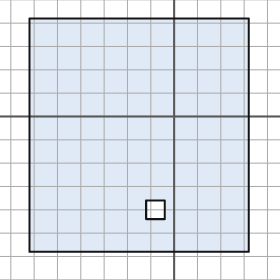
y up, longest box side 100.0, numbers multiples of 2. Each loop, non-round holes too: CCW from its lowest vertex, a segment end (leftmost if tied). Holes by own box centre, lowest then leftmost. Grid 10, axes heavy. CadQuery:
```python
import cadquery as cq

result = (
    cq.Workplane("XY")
    .moveTo(-62.0, -58.0)
    .lineTo(32.0, -58.0)
    .lineTo(32.0, 42.0)
    .lineTo(-62.0, 42.0)
    .close()
    .moveTo(-12.0, -44.0)
    .lineTo(-4.0, -44.0)
    .lineTo(-4.0, -36.0)
    .lineTo(-12.0, -36.0)
    .close()
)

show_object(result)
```